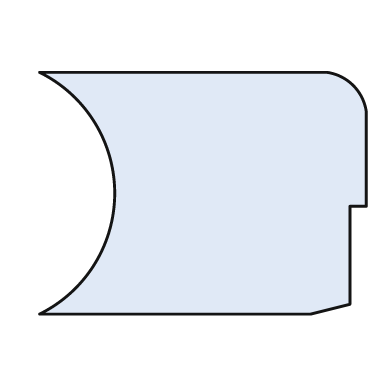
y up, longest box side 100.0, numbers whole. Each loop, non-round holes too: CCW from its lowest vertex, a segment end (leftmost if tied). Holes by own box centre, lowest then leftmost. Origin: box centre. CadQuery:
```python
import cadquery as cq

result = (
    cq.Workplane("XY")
    .moveTo(-50.0, -37.0)
    .lineTo(33.0, -37.0)
    .lineTo(45.0, -34.0)
    .lineTo(45.0, -4.0)
    .lineTo(50.0, -4.0)
    .lineTo(50.0, 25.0)
    .threePointArc((46.0, 33.0), (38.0, 37.0))
    .lineTo(-50.0, 37.0)
    .threePointArc((-27.0, 0.0), (-50.0, -37.0))
    .close()
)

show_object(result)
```